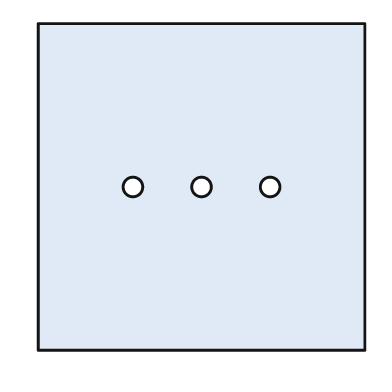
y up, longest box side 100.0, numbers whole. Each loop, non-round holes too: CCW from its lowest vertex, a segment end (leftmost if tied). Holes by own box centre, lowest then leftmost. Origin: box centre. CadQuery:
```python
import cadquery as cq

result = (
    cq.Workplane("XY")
    .moveTo(-50.0, -50.0)
    .lineTo(50.0, -50.0)
    .lineTo(50.0, 50.0)
    .lineTo(-50.0, 50.0)
    .close()
    .moveTo(-21.0, 0.0)
    .circle(3.0)
    .moveTo(0.0, 0.0)
    .circle(3.0)
    .moveTo(21.0, 0.0)
    .circle(3.0)
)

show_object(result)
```